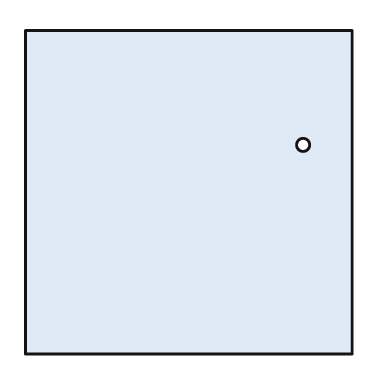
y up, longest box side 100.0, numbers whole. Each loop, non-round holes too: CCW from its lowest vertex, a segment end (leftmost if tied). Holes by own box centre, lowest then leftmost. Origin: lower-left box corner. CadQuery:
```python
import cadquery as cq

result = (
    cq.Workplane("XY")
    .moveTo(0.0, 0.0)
    .lineTo(100.0, 0.0)
    .lineTo(100.0, 99.0)
    .lineTo(0.0, 99.0)
    .close()
    .moveTo(85.0, 64.0)
    .circle(2.0)
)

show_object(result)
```